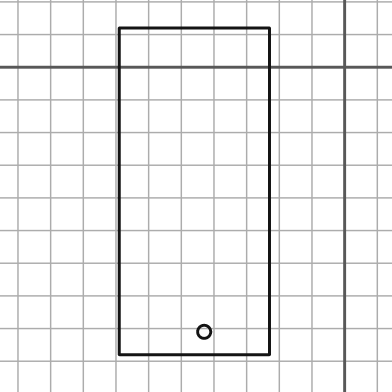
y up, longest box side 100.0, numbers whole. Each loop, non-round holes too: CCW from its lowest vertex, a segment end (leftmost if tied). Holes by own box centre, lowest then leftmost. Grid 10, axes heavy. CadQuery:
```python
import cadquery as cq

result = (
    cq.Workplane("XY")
    .moveTo(-69.0, -88.0)
    .lineTo(-23.0, -88.0)
    .lineTo(-23.0, 12.0)
    .lineTo(-69.0, 12.0)
    .close()
    .moveTo(-43.0, -81.0)
    .circle(2.0)
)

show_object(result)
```